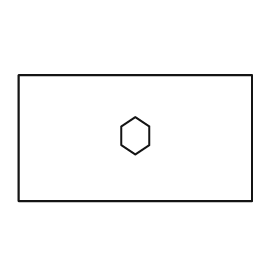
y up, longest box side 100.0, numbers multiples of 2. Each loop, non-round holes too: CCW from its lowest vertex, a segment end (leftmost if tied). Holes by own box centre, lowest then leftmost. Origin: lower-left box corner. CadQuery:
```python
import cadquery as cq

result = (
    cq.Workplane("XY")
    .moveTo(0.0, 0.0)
    .lineTo(100.0, 0.0)
    .lineTo(100.0, 54.0)
    .lineTo(0.0, 54.0)
    .close()
    .moveTo(50.0, 20.0)
    .lineTo(56.0, 24.0)
    .lineTo(56.0, 32.0)
    .lineTo(50.0, 36.0)
    .lineTo(44.0, 32.0)
    .lineTo(44.0, 24.0)
    .close()
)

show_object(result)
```